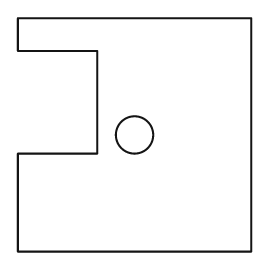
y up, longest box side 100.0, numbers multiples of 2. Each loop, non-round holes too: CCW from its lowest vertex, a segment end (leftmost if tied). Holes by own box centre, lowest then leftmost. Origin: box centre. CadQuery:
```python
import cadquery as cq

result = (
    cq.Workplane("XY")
    .moveTo(-50.0, -50.0)
    .lineTo(50.0, -50.0)
    .lineTo(50.0, 50.0)
    .lineTo(-50.0, 50.0)
    .lineTo(-50.0, 36.0)
    .lineTo(-16.0, 36.0)
    .lineTo(-16.0, -8.0)
    .lineTo(-50.0, -8.0)
    .close()
    .moveTo(0.0, 0.0)
    .circle(8.0)
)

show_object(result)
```